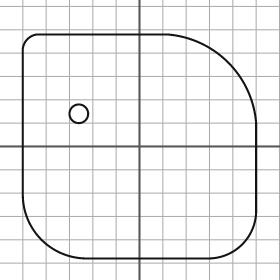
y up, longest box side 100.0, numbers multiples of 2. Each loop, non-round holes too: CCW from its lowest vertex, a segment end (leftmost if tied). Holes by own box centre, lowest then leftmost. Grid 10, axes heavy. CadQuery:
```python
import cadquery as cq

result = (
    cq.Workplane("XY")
    .moveTo(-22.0, -48.0)
    .lineTo(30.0, -48.0)
    .threePointArc((44.0, -42.0), (50.0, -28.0))
    .lineTo(50.0, 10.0)
    .threePointArc((38.0, 36.0), (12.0, 48.0))
    .lineTo(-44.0, 48.0)
    .threePointArc((-48.0, 46.0), (-50.0, 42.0))
    .lineTo(-50.0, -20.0)
    .threePointArc((-42.0, -40.0), (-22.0, -48.0))
    .close()
    .moveTo(-26.0, 14.0)
    .circle(4.0)
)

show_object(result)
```